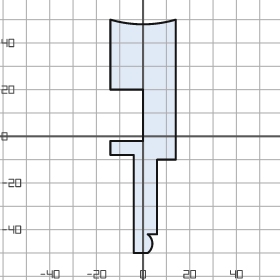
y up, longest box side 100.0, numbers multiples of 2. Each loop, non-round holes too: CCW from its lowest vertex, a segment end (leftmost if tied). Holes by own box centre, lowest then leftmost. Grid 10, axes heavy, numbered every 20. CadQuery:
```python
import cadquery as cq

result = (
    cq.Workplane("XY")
    .moveTo(-4.0, -50.0)
    .lineTo(2.0, -50.0)
    .threePointArc((4.0, -46.0), (2.0, -42.0))
    .lineTo(6.0, -42.0)
    .lineTo(6.0, -10.0)
    .lineTo(14.0, -10.0)
    .lineTo(14.0, 50.0)
    .threePointArc((0.0, 48.0), (-14.0, 50.0))
    .lineTo(-14.0, 20.0)
    .lineTo(0.0, 20.0)
    .lineTo(0.0, -2.0)
    .lineTo(-14.0, -2.0)
    .lineTo(-14.0, -8.0)
    .lineTo(-4.0, -8.0)
    .close()
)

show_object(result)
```